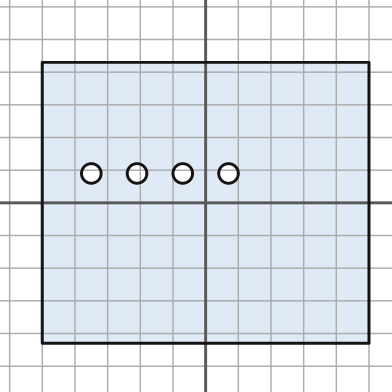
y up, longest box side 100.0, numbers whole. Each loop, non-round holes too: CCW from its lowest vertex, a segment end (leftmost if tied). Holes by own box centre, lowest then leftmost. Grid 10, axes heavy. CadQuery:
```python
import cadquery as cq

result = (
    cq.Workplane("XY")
    .moveTo(-50.0, -43.0)
    .lineTo(50.0, -43.0)
    .lineTo(50.0, 43.0)
    .lineTo(-50.0, 43.0)
    .close()
    .moveTo(-35.0, 9.0)
    .circle(3.0)
    .moveTo(-21.0, 9.0)
    .circle(3.0)
    .moveTo(-7.0, 9.0)
    .circle(3.0)
    .moveTo(7.0, 9.0)
    .circle(3.0)
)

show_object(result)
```